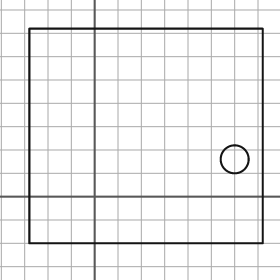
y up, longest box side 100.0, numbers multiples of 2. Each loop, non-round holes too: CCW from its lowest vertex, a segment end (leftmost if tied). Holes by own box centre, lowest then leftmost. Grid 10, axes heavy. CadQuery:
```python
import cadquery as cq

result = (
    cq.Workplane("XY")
    .moveTo(-28.0, -20.0)
    .lineTo(72.0, -20.0)
    .lineTo(72.0, 72.0)
    .lineTo(-28.0, 72.0)
    .close()
    .moveTo(60.0, 16.0)
    .circle(6.0)
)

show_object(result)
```